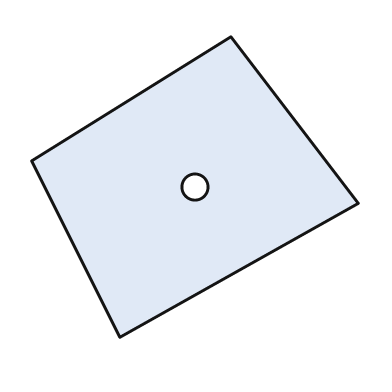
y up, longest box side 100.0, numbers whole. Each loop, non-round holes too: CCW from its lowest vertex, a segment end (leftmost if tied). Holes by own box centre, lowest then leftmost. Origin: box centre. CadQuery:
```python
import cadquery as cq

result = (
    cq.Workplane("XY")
    .moveTo(-23.0, -46.0)
    .lineTo(50.0, -5.0)
    .lineTo(11.0, 46.0)
    .lineTo(-50.0, 8.0)
    .close()
    .moveTo(0.0, 0.0)
    .circle(4.0)
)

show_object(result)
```